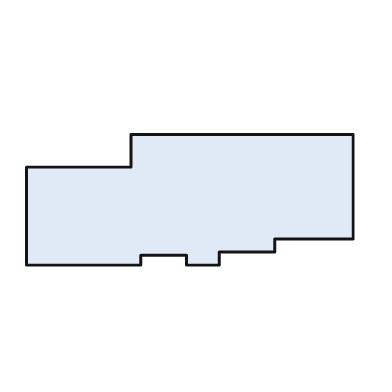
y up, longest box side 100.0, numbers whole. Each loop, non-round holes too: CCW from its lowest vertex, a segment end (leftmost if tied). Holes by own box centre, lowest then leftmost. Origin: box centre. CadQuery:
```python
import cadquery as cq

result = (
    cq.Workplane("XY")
    .moveTo(-50.0, -20.0)
    .lineTo(-15.0, -20.0)
    .lineTo(-15.0, -17.0)
    .lineTo(-1.0, -17.0)
    .lineTo(-1.0, -20.0)
    .lineTo(9.0, -20.0)
    .lineTo(9.0, -16.0)
    .lineTo(26.0, -16.0)
    .lineTo(26.0, -12.0)
    .lineTo(50.0, -12.0)
    .lineTo(50.0, 20.0)
    .lineTo(-18.0, 20.0)
    .lineTo(-18.0, 10.0)
    .lineTo(-50.0, 10.0)
    .close()
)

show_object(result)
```